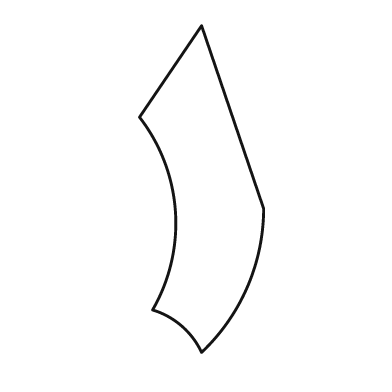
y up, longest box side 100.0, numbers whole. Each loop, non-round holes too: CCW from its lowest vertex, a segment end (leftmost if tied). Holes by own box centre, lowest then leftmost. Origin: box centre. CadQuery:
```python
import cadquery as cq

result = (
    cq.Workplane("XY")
    .moveTo(0.0, -50.0)
    .threePointArc((14.0, -30.0), (19.0, -6.0))
    .lineTo(0.0, 50.0)
    .lineTo(-19.0, 22.0)
    .threePointArc((-8.0, -7.0), (-15.0, -37.0))
    .threePointArc((-6.0, -42.0), (0.0, -50.0))
    .close()
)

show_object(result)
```